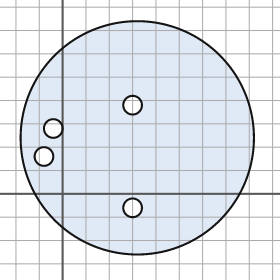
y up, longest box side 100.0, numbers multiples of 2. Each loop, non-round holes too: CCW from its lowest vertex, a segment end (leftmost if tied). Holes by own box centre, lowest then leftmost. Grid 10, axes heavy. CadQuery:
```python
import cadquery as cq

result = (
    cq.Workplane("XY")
    .moveTo(32.0, 24.0)
    .circle(50.0)
    .moveTo(30.0, -6.0)
    .circle(4.0)
    .moveTo(-8.0, 16.0)
    .circle(4.0)
    .moveTo(-4.0, 28.0)
    .circle(4.0)
    .moveTo(30.0, 38.0)
    .circle(4.0)
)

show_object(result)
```